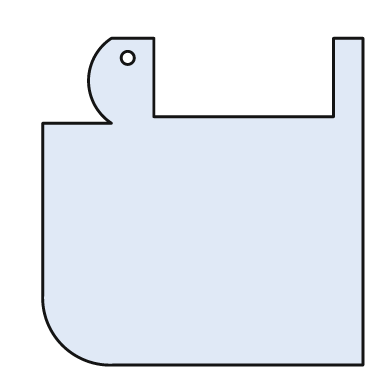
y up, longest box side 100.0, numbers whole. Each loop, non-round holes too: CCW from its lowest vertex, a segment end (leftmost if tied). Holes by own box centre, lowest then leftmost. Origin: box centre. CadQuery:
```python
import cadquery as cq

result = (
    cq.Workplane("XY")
    .moveTo(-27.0, -50.0)
    .lineTo(49.0, -50.0)
    .lineTo(49.0, 50.0)
    .lineTo(40.0, 50.0)
    .lineTo(40.0, 26.0)
    .lineTo(-15.0, 26.0)
    .lineTo(-15.0, 50.0)
    .lineTo(-28.0, 50.0)
    .threePointArc((-35.0, 37.0), (-28.0, 24.0))
    .lineTo(-49.0, 24.0)
    .lineTo(-49.0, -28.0)
    .threePointArc((-43.0, -44.0), (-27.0, -50.0))
    .close()
    .moveTo(-23.0, 44.0)
    .circle(2.0)
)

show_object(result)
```